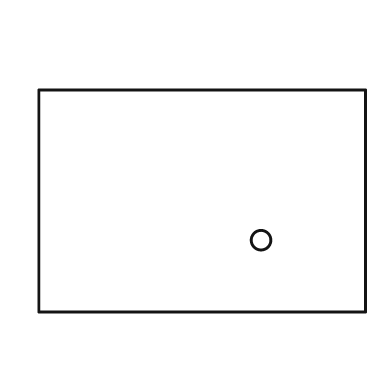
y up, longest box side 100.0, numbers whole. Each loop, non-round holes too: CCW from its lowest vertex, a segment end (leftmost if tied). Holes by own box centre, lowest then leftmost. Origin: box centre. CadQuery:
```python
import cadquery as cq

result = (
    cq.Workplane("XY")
    .moveTo(-50.0, -34.0)
    .lineTo(50.0, -34.0)
    .lineTo(50.0, 34.0)
    .lineTo(-50.0, 34.0)
    .close()
    .moveTo(18.0, -12.0)
    .circle(3.0)
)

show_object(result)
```